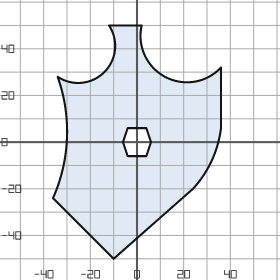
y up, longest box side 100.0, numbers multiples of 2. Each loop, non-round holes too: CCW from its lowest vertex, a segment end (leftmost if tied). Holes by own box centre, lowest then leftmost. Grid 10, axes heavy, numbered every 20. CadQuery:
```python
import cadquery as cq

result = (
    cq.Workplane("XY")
    .moveTo(-10.0, -50.0)
    .lineTo(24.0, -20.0)
    .threePointArc((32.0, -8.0), (36.0, 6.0))
    .lineTo(36.0, 32.0)
    .threePointArc((12.0, 28.0), (2.0, 50.0))
    .lineTo(-12.0, 50.0)
    .threePointArc((-14.0, 30.0), (-34.0, 28.0))
    .threePointArc((-30.0, 2.0), (-36.0, -24.0))
    .close()
    .moveTo(-4.0, -6.0)
    .lineTo(4.0, -6.0)
    .lineTo(6.0, 0.0)
    .lineTo(4.0, 6.0)
    .lineTo(-4.0, 6.0)
    .lineTo(-6.0, 0.0)
    .close()
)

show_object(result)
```